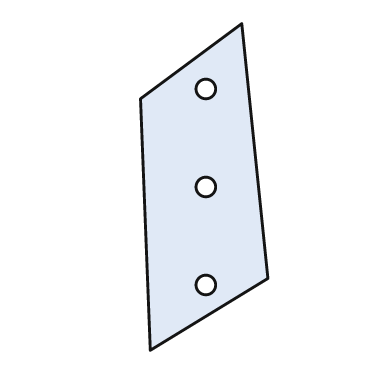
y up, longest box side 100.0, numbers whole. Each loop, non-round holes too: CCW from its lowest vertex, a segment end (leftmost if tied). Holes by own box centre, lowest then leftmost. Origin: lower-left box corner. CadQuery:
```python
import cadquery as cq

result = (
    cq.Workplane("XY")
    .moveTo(3.0, 0.0)
    .lineTo(39.0, 22.0)
    .lineTo(31.0, 100.0)
    .lineTo(0.0, 77.0)
    .close()
    .moveTo(20.0, 20.0)
    .circle(3.0)
    .moveTo(20.0, 50.0)
    .circle(3.0)
    .moveTo(20.0, 80.0)
    .circle(3.0)
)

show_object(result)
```